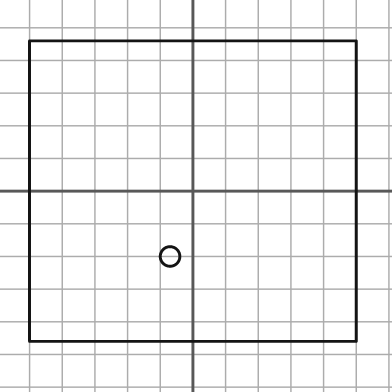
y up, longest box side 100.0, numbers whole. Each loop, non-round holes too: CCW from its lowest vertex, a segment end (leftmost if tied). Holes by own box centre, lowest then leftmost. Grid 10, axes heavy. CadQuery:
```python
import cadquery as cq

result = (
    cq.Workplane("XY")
    .moveTo(-50.0, -46.0)
    .lineTo(50.0, -46.0)
    .lineTo(50.0, 46.0)
    .lineTo(-50.0, 46.0)
    .close()
    .moveTo(-7.0, -20.0)
    .circle(3.0)
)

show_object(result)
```